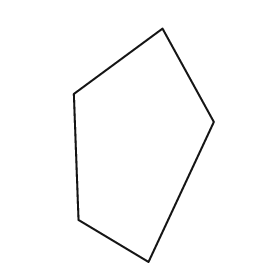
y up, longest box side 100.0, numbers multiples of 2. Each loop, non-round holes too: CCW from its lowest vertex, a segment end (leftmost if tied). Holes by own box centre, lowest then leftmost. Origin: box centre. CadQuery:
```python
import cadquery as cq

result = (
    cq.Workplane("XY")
    .moveTo(2.0, -50.0)
    .lineTo(30.0, 10.0)
    .lineTo(8.0, 50.0)
    .lineTo(-30.0, 22.0)
    .lineTo(-28.0, -32.0)
    .close()
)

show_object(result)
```